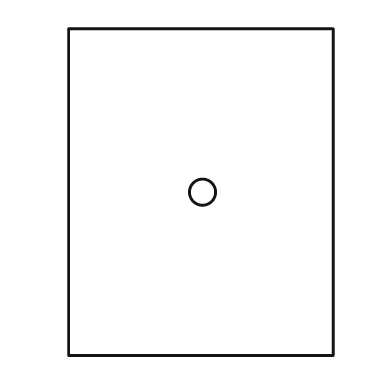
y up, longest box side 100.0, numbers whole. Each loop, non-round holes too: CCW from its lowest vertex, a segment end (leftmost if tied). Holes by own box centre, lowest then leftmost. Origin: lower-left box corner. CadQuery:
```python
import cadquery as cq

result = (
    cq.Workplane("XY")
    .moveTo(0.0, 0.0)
    .lineTo(81.0, 0.0)
    .lineTo(81.0, 100.0)
    .lineTo(0.0, 100.0)
    .close()
    .moveTo(41.0, 50.0)
    .circle(4.0)
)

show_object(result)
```